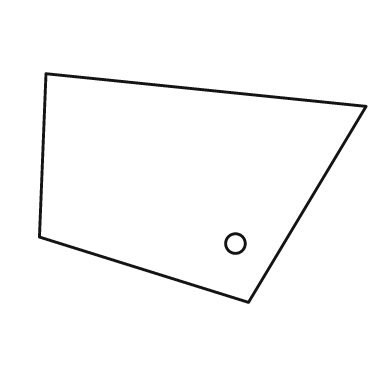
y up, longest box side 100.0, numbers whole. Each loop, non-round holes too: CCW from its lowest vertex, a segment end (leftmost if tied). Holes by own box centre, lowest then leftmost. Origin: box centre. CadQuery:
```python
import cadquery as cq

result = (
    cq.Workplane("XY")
    .moveTo(14.0, -35.0)
    .lineTo(50.0, 25.0)
    .lineTo(-48.0, 35.0)
    .lineTo(-50.0, -15.0)
    .close()
    .moveTo(10.0, -17.0)
    .circle(3.0)
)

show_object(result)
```